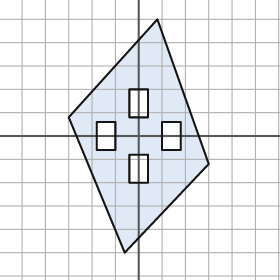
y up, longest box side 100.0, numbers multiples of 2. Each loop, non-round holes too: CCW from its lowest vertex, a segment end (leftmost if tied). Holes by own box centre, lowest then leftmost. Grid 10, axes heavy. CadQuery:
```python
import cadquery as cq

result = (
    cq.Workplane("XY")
    .moveTo(-6.0, -50.0)
    .lineTo(30.0, -12.0)
    .lineTo(8.0, 50.0)
    .lineTo(-30.0, 8.0)
    .close()
    .moveTo(-4.0, -20.0)
    .lineTo(4.0, -20.0)
    .lineTo(4.0, -8.0)
    .lineTo(-4.0, -8.0)
    .close()
    .moveTo(-18.0, -6.0)
    .lineTo(-10.0, -6.0)
    .lineTo(-10.0, 6.0)
    .lineTo(-18.0, 6.0)
    .close()
    .moveTo(10.0, -6.0)
    .lineTo(18.0, -6.0)
    .lineTo(18.0, 6.0)
    .lineTo(10.0, 6.0)
    .close()
    .moveTo(-4.0, 8.0)
    .lineTo(4.0, 8.0)
    .lineTo(4.0, 20.0)
    .lineTo(-4.0, 20.0)
    .close()
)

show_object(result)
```